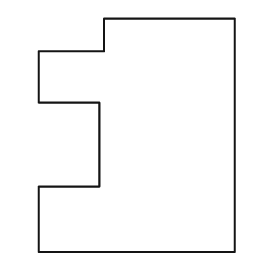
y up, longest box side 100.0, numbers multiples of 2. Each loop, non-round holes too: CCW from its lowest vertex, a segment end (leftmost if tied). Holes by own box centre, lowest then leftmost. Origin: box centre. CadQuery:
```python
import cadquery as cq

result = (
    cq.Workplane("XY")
    .moveTo(-42.0, -50.0)
    .lineTo(42.0, -50.0)
    .lineTo(42.0, 50.0)
    .lineTo(-14.0, 50.0)
    .lineTo(-14.0, 36.0)
    .lineTo(-42.0, 36.0)
    .lineTo(-42.0, 14.0)
    .lineTo(-16.0, 14.0)
    .lineTo(-16.0, -22.0)
    .lineTo(-42.0, -22.0)
    .close()
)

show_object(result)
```